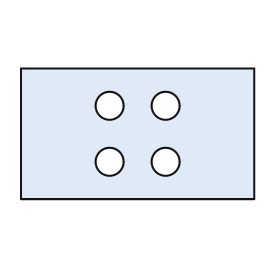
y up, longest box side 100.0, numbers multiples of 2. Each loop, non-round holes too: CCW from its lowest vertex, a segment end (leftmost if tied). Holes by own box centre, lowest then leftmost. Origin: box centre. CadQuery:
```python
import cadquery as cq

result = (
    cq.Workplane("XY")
    .moveTo(-50.0, -28.0)
    .lineTo(50.0, -28.0)
    .lineTo(50.0, 28.0)
    .lineTo(-50.0, 28.0)
    .close()
    .moveTo(-12.0, -12.0)
    .circle(6.0)
    .moveTo(12.0, -12.0)
    .circle(6.0)
    .moveTo(-12.0, 12.0)
    .circle(6.0)
    .moveTo(12.0, 12.0)
    .circle(6.0)
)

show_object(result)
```